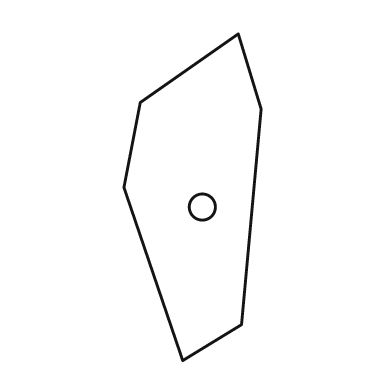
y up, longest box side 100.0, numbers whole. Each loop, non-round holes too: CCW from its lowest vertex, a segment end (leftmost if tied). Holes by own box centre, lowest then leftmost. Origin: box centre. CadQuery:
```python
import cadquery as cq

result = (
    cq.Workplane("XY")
    .moveTo(-3.0, -50.0)
    .lineTo(15.0, -39.0)
    .lineTo(21.0, 27.0)
    .lineTo(14.0, 50.0)
    .lineTo(-16.0, 29.0)
    .lineTo(-21.0, 3.0)
    .close()
    .moveTo(3.0, -3.0)
    .circle(4.0)
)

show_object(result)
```